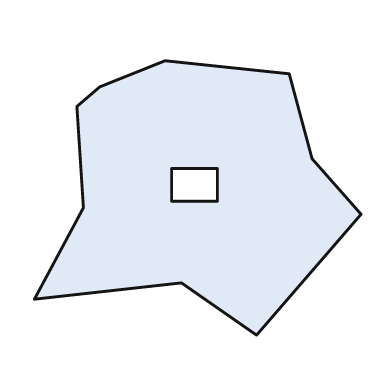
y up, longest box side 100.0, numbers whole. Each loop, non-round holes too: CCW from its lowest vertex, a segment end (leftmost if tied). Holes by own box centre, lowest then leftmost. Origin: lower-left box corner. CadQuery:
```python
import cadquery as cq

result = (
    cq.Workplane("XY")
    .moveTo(68.0, 0.0)
    .lineTo(100.0, 37.0)
    .lineTo(85.0, 54.0)
    .lineTo(78.0, 80.0)
    .lineTo(40.0, 84.0)
    .lineTo(20.0, 76.0)
    .lineTo(13.0, 70.0)
    .lineTo(15.0, 39.0)
    .lineTo(0.0, 11.0)
    .lineTo(45.0, 16.0)
    .close()
    .moveTo(42.0, 41.0)
    .lineTo(56.0, 41.0)
    .lineTo(56.0, 51.0)
    .lineTo(42.0, 51.0)
    .close()
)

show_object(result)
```